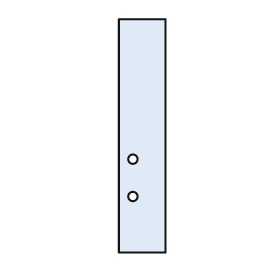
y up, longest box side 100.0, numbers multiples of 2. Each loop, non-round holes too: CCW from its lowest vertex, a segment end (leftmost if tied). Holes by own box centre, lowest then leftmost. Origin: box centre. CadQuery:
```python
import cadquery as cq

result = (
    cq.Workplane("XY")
    .moveTo(-10.0, -50.0)
    .lineTo(10.0, -50.0)
    .lineTo(10.0, 50.0)
    .lineTo(-10.0, 50.0)
    .close()
    .moveTo(-4.0, -26.0)
    .circle(2.0)
    .moveTo(-4.0, -10.0)
    .circle(2.0)
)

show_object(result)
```